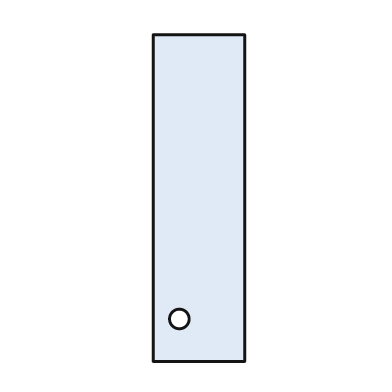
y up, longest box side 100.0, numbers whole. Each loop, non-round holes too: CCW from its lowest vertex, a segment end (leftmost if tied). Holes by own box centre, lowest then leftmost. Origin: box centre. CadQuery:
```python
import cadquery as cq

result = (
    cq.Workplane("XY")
    .moveTo(-14.0, -50.0)
    .lineTo(14.0, -50.0)
    .lineTo(14.0, 50.0)
    .lineTo(-14.0, 50.0)
    .close()
    .moveTo(-6.0, -37.0)
    .circle(3.0)
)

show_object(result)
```